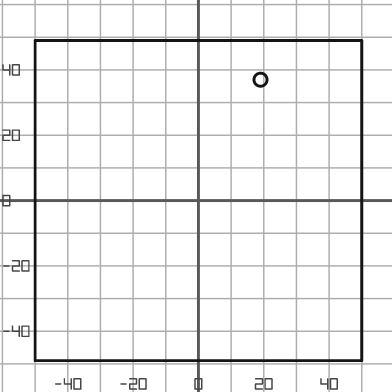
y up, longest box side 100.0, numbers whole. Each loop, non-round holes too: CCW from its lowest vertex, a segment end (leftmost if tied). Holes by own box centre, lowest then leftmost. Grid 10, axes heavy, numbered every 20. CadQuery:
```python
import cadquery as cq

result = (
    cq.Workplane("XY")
    .moveTo(-50.0, -49.0)
    .lineTo(50.0, -49.0)
    .lineTo(50.0, 49.0)
    .lineTo(-50.0, 49.0)
    .close()
    .moveTo(19.0, 37.0)
    .circle(2.0)
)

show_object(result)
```